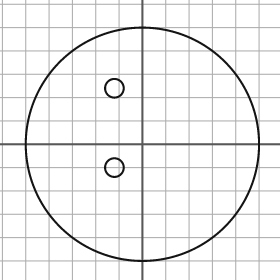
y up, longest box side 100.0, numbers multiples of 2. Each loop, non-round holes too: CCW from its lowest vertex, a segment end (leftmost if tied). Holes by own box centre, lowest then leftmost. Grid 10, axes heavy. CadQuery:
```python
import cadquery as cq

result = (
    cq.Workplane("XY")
    .moveTo(0.0, 0.0)
    .circle(50.0)
    .moveTo(-12.0, -10.0)
    .circle(4.0)
    .moveTo(-12.0, 24.0)
    .circle(4.0)
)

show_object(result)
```